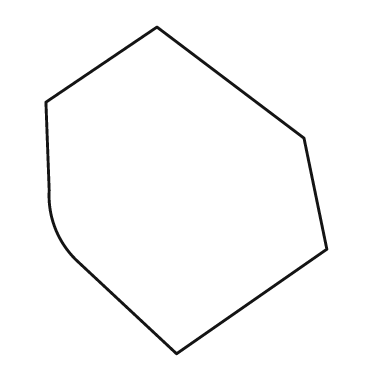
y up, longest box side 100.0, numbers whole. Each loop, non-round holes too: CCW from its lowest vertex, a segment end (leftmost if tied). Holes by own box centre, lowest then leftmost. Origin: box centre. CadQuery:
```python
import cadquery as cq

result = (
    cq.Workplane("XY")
    .moveTo(-3.0, -50.0)
    .lineTo(43.0, -18.0)
    .lineTo(36.0, 16.0)
    .lineTo(-9.0, 50.0)
    .lineTo(-43.0, 27.0)
    .lineTo(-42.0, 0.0)
    .threePointArc((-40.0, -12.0), (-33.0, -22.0))
    .close()
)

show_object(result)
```